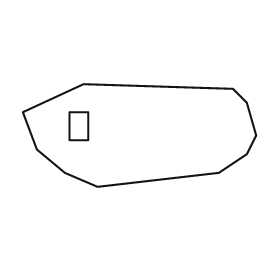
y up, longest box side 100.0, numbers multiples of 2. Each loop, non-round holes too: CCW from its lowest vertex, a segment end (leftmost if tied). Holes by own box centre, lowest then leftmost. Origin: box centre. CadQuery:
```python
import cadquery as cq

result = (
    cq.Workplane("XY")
    .moveTo(-18.0, -22.0)
    .lineTo(34.0, -16.0)
    .lineTo(46.0, -8.0)
    .lineTo(50.0, 0.0)
    .lineTo(46.0, 14.0)
    .lineTo(40.0, 20.0)
    .lineTo(-24.0, 22.0)
    .lineTo(-50.0, 10.0)
    .lineTo(-44.0, -6.0)
    .lineTo(-32.0, -16.0)
    .close()
    .moveTo(-30.0, -2.0)
    .lineTo(-22.0, -2.0)
    .lineTo(-22.0, 10.0)
    .lineTo(-30.0, 10.0)
    .close()
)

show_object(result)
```